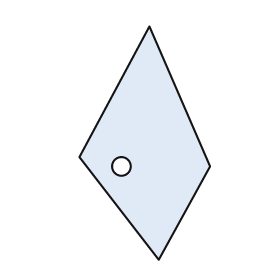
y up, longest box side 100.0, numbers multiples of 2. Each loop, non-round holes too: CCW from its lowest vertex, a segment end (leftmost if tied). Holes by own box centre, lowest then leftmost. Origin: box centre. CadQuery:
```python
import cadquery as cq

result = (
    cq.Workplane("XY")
    .moveTo(6.0, -50.0)
    .lineTo(28.0, -10.0)
    .lineTo(2.0, 50.0)
    .lineTo(-28.0, -6.0)
    .close()
    .moveTo(-10.0, -10.0)
    .circle(4.0)
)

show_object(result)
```